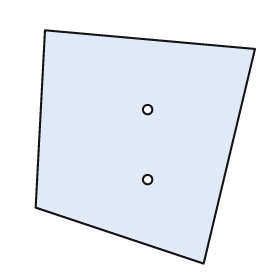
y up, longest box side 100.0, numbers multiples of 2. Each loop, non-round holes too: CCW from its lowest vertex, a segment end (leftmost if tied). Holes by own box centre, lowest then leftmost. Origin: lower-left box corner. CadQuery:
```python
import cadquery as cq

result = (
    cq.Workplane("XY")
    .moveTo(72.0, 0.0)
    .lineTo(94.0, 92.0)
    .lineTo(4.0, 100.0)
    .lineTo(0.0, 24.0)
    .close()
    .moveTo(48.0, 36.0)
    .circle(2.0)
    .moveTo(48.0, 66.0)
    .circle(2.0)
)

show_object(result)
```